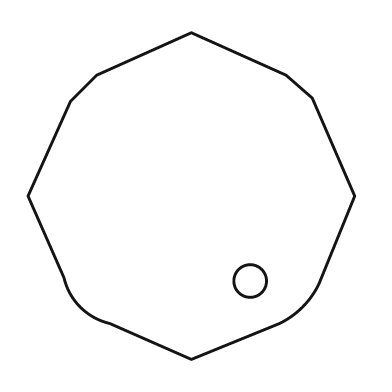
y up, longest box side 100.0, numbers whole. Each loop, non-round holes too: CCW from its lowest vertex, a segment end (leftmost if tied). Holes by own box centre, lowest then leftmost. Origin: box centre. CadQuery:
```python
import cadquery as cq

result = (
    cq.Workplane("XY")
    .moveTo(0.0, -50.0)
    .lineTo(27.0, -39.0)
    .threePointArc((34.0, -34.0), (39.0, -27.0))
    .lineTo(50.0, 0.0)
    .lineTo(37.0, 30.0)
    .lineTo(29.0, 37.0)
    .lineTo(0.0, 50.0)
    .lineTo(-29.0, 37.0)
    .lineTo(-37.0, 29.0)
    .lineTo(-50.0, 0.0)
    .lineTo(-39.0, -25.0)
    .threePointArc((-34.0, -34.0), (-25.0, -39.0))
    .close()
    .moveTo(18.0, -26.0)
    .circle(5.0)
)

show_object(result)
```